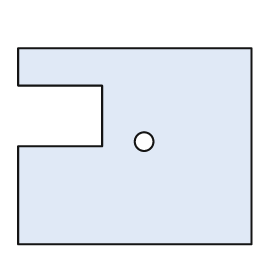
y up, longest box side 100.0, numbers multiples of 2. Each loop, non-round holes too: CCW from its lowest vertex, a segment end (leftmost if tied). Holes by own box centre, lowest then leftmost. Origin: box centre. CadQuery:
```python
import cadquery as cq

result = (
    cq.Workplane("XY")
    .moveTo(-50.0, -42.0)
    .lineTo(50.0, -42.0)
    .lineTo(50.0, 42.0)
    .lineTo(-50.0, 42.0)
    .lineTo(-50.0, 26.0)
    .lineTo(-14.0, 26.0)
    .lineTo(-14.0, 0.0)
    .lineTo(-50.0, 0.0)
    .close()
    .moveTo(4.0, 2.0)
    .circle(4.0)
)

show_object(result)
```